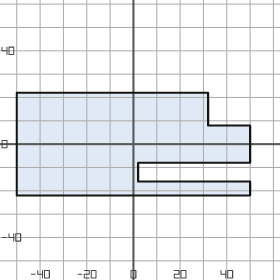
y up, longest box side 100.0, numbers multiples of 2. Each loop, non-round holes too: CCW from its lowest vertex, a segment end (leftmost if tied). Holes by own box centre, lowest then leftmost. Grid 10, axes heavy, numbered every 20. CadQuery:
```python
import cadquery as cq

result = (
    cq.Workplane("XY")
    .moveTo(-50.0, -22.0)
    .lineTo(50.0, -22.0)
    .lineTo(50.0, -16.0)
    .lineTo(2.0, -16.0)
    .lineTo(2.0, -8.0)
    .lineTo(50.0, -8.0)
    .lineTo(50.0, 8.0)
    .lineTo(32.0, 8.0)
    .lineTo(32.0, 22.0)
    .lineTo(-50.0, 22.0)
    .close()
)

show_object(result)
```